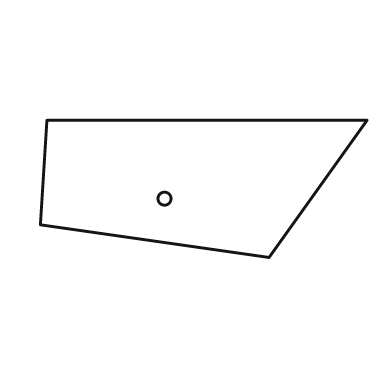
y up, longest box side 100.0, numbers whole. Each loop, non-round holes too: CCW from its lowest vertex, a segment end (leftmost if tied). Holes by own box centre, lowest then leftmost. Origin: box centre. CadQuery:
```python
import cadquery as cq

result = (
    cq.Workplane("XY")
    .moveTo(20.0, -21.0)
    .lineTo(50.0, 21.0)
    .lineTo(-48.0, 21.0)
    .lineTo(-50.0, -11.0)
    .close()
    .moveTo(-12.0, -3.0)
    .circle(2.0)
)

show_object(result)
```